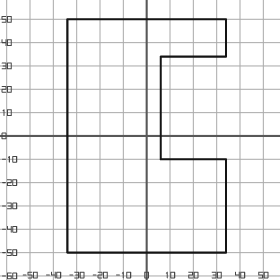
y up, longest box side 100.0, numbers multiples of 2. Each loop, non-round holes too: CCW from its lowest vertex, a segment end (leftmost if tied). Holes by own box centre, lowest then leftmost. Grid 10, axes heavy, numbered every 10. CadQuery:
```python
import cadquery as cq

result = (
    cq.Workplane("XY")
    .moveTo(-34.0, -50.0)
    .lineTo(34.0, -50.0)
    .lineTo(34.0, -10.0)
    .lineTo(6.0, -10.0)
    .lineTo(6.0, 34.0)
    .lineTo(34.0, 34.0)
    .lineTo(34.0, 50.0)
    .lineTo(-34.0, 50.0)
    .close()
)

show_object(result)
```